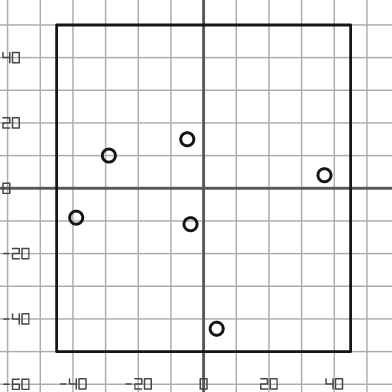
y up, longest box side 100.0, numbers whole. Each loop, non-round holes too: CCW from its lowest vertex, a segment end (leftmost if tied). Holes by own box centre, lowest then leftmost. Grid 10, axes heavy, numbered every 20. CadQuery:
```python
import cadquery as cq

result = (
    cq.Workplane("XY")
    .moveTo(-45.0, -50.0)
    .lineTo(45.0, -50.0)
    .lineTo(45.0, 50.0)
    .lineTo(-45.0, 50.0)
    .close()
    .moveTo(4.0, -43.0)
    .circle(2.0)
    .moveTo(-4.0, -11.0)
    .circle(2.0)
    .moveTo(-39.0, -9.0)
    .circle(2.0)
    .moveTo(37.0, 4.0)
    .circle(2.0)
    .moveTo(-29.0, 10.0)
    .circle(2.0)
    .moveTo(-5.0, 15.0)
    .circle(2.0)
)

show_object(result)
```